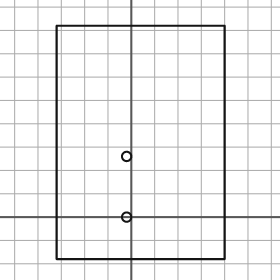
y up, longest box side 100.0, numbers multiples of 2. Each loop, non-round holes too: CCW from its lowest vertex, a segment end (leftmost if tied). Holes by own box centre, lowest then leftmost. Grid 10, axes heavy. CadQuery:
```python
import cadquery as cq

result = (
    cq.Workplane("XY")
    .moveTo(-32.0, -18.0)
    .lineTo(40.0, -18.0)
    .lineTo(40.0, 82.0)
    .lineTo(-32.0, 82.0)
    .close()
    .moveTo(-2.0, 0.0)
    .circle(2.0)
    .moveTo(-2.0, 26.0)
    .circle(2.0)
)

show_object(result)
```